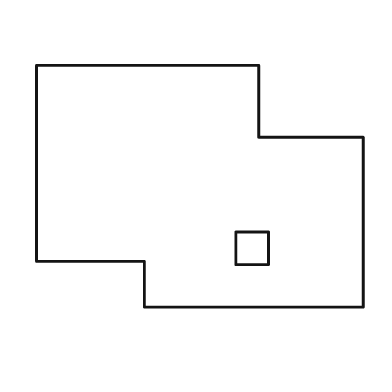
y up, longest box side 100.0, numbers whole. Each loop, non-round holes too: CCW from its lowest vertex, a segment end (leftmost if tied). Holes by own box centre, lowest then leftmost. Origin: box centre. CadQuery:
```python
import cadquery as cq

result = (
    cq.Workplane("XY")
    .moveTo(-17.0, -37.0)
    .lineTo(50.0, -37.0)
    .lineTo(50.0, 15.0)
    .lineTo(18.0, 15.0)
    .lineTo(18.0, 37.0)
    .lineTo(-50.0, 37.0)
    .lineTo(-50.0, -23.0)
    .lineTo(-17.0, -23.0)
    .close()
    .moveTo(11.0, -24.0)
    .lineTo(21.0, -24.0)
    .lineTo(21.0, -14.0)
    .lineTo(11.0, -14.0)
    .close()
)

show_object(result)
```